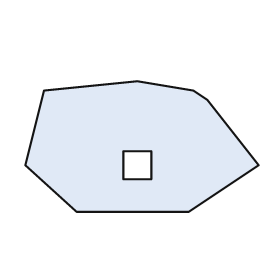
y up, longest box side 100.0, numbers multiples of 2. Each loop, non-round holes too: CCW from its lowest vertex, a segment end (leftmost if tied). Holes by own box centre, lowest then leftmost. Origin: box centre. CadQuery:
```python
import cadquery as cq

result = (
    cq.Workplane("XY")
    .moveTo(-28.0, -28.0)
    .lineTo(20.0, -28.0)
    .lineTo(50.0, -8.0)
    .lineTo(28.0, 20.0)
    .lineTo(22.0, 24.0)
    .lineTo(-2.0, 28.0)
    .lineTo(-42.0, 24.0)
    .lineTo(-50.0, -8.0)
    .close()
    .moveTo(-8.0, -14.0)
    .lineTo(4.0, -14.0)
    .lineTo(4.0, -2.0)
    .lineTo(-8.0, -2.0)
    .close()
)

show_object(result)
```